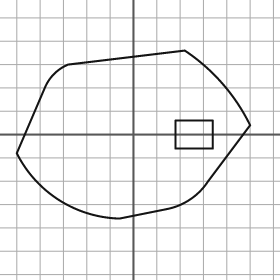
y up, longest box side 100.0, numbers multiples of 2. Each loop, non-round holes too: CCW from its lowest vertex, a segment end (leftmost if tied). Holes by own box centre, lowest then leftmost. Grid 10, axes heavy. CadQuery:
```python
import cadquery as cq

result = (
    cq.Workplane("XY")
    .moveTo(-6.0, -36.0)
    .lineTo(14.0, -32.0)
    .threePointArc((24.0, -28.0), (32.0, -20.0))
    .lineTo(50.0, 4.0)
    .threePointArc((38.0, 22.0), (22.0, 36.0))
    .lineTo(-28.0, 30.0)
    .threePointArc((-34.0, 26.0), (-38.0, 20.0))
    .lineTo(-50.0, -8.0)
    .threePointArc((-32.0, -28.0), (-6.0, -36.0))
    .close()
    .moveTo(18.0, -6.0)
    .lineTo(34.0, -6.0)
    .lineTo(34.0, 6.0)
    .lineTo(18.0, 6.0)
    .close()
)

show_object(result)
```